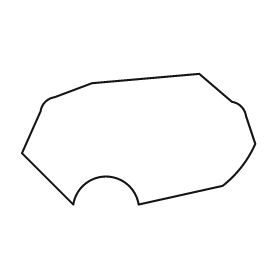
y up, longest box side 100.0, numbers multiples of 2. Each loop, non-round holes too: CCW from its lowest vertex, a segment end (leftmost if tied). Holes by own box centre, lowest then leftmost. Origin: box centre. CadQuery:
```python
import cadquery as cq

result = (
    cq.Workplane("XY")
    .moveTo(-28.0, -28.0)
    .threePointArc((-14.0, -16.0), (0.0, -28.0))
    .lineTo(36.0, -20.0)
    .threePointArc((44.0, -12.0), (50.0, -2.0))
    .lineTo(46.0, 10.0)
    .threePointArc((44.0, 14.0), (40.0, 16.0))
    .lineTo(26.0, 28.0)
    .lineTo(-20.0, 24.0)
    .lineTo(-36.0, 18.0)
    .threePointArc((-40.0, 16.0), (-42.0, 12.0))
    .lineTo(-50.0, -6.0)
    .close()
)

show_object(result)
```